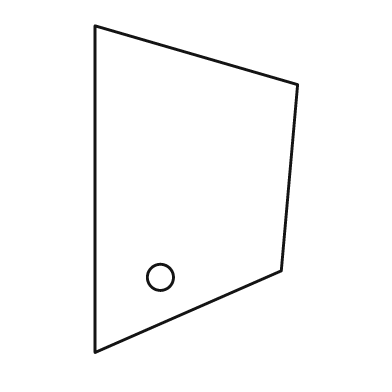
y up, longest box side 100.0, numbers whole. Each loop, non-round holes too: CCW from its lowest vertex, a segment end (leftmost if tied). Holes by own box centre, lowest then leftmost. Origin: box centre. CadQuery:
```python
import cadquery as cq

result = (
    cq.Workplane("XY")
    .moveTo(-31.0, -50.0)
    .lineTo(26.0, -25.0)
    .lineTo(31.0, 32.0)
    .lineTo(-31.0, 50.0)
    .close()
    .moveTo(-11.0, -27.0)
    .circle(4.0)
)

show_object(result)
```